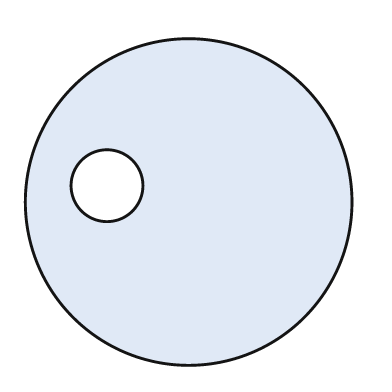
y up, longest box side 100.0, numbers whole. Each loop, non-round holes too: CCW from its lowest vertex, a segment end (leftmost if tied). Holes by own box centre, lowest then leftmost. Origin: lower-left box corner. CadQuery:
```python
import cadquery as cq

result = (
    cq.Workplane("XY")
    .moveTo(50.0, 50.0)
    .circle(50.0)
    .moveTo(25.0, 55.0)
    .circle(11.0)
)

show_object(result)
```